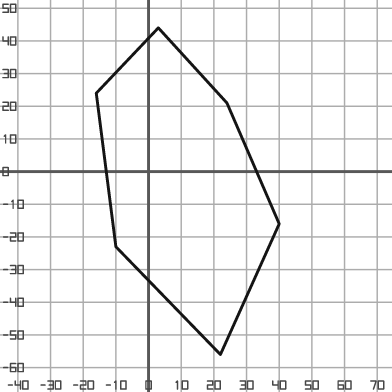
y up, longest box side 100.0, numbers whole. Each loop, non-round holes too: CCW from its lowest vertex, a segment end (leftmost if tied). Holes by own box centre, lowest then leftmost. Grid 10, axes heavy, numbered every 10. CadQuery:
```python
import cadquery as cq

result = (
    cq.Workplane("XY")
    .moveTo(22.0, -56.0)
    .lineTo(40.0, -16.0)
    .lineTo(24.0, 21.0)
    .lineTo(3.0, 44.0)
    .lineTo(-16.0, 24.0)
    .lineTo(-10.0, -23.0)
    .close()
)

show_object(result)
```